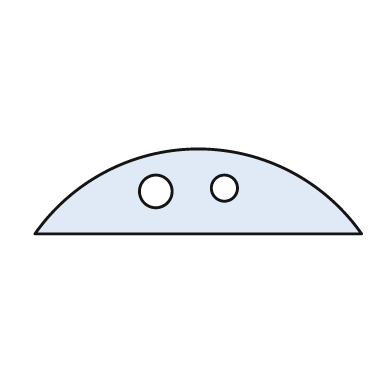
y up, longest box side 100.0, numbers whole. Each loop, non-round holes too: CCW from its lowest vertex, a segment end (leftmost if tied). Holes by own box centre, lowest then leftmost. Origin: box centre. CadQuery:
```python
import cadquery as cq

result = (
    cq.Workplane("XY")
    .moveTo(-50.0, -13.0)
    .lineTo(50.0, -13.0)
    .threePointArc((0.0, 13.0), (-50.0, -13.0))
    .close()
    .moveTo(-13.0, 0.0)
    .circle(5.0)
    .moveTo(8.0, 1.0)
    .circle(4.0)
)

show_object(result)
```